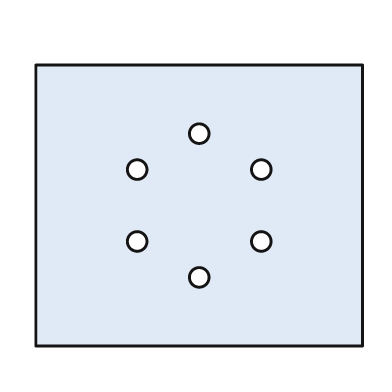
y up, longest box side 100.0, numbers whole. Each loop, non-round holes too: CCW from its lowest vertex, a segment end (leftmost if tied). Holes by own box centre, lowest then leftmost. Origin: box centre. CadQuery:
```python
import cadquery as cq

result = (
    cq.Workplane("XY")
    .moveTo(-50.0, -43.0)
    .lineTo(50.0, -43.0)
    .lineTo(50.0, 43.0)
    .lineTo(-50.0, 43.0)
    .close()
    .moveTo(0.0, -22.0)
    .circle(3.0)
    .moveTo(-19.0, -11.0)
    .circle(3.0)
    .moveTo(19.0, -11.0)
    .circle(3.0)
    .moveTo(-19.0, 11.0)
    .circle(3.0)
    .moveTo(19.0, 11.0)
    .circle(3.0)
    .moveTo(0.0, 22.0)
    .circle(3.0)
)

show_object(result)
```